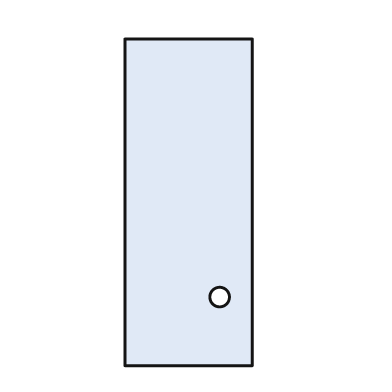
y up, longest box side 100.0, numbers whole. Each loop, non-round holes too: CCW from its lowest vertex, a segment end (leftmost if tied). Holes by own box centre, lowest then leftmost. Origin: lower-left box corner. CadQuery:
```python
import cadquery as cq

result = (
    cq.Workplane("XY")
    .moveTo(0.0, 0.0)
    .lineTo(39.0, 0.0)
    .lineTo(39.0, 100.0)
    .lineTo(0.0, 100.0)
    .close()
    .moveTo(29.0, 21.0)
    .circle(3.0)
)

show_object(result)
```